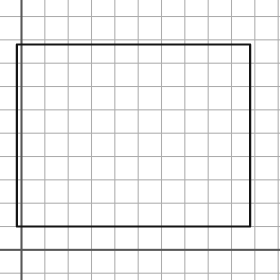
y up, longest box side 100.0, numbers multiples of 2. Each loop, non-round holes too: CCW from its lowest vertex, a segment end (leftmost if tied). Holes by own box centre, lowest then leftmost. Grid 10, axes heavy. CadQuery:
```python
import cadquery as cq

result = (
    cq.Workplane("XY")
    .moveTo(-2.0, 10.0)
    .lineTo(98.0, 10.0)
    .lineTo(98.0, 88.0)
    .lineTo(-2.0, 88.0)
    .close()
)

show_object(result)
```